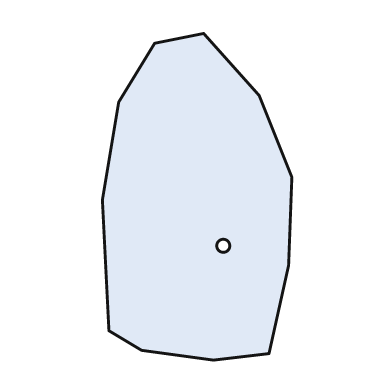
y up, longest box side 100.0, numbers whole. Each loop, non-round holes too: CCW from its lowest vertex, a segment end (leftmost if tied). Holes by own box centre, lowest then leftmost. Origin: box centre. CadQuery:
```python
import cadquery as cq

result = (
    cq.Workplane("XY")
    .moveTo(5.0, -50.0)
    .lineTo(22.0, -48.0)
    .lineTo(28.0, -21.0)
    .lineTo(29.0, 6.0)
    .lineTo(19.0, 31.0)
    .lineTo(2.0, 50.0)
    .lineTo(-13.0, 47.0)
    .lineTo(-24.0, 29.0)
    .lineTo(-29.0, -1.0)
    .lineTo(-27.0, -41.0)
    .lineTo(-17.0, -47.0)
    .close()
    .moveTo(8.0, -15.0)
    .circle(2.0)
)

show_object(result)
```